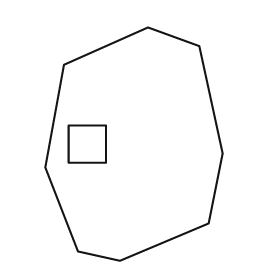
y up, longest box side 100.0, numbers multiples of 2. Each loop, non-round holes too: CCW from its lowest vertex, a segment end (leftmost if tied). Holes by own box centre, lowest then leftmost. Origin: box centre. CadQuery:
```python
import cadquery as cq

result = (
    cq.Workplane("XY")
    .moveTo(-6.0, -50.0)
    .lineTo(32.0, -34.0)
    .lineTo(38.0, -4.0)
    .lineTo(28.0, 42.0)
    .lineTo(6.0, 50.0)
    .lineTo(-30.0, 34.0)
    .lineTo(-38.0, -10.0)
    .lineTo(-24.0, -46.0)
    .close()
    .moveTo(-28.0, -8.0)
    .lineTo(-12.0, -8.0)
    .lineTo(-12.0, 8.0)
    .lineTo(-28.0, 8.0)
    .close()
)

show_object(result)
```